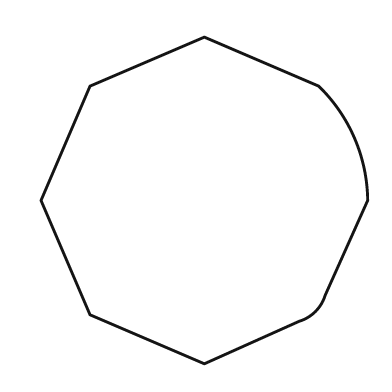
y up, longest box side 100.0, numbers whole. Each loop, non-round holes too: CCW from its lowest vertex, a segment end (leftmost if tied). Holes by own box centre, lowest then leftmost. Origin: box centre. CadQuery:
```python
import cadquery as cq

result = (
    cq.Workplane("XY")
    .moveTo(0.0, -50.0)
    .lineTo(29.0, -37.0)
    .threePointArc((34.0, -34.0), (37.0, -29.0))
    .lineTo(50.0, 0.0)
    .threePointArc((46.0, 19.0), (35.0, 35.0))
    .lineTo(0.0, 50.0)
    .lineTo(-35.0, 35.0)
    .lineTo(-50.0, 0.0)
    .lineTo(-35.0, -35.0)
    .close()
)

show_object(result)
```